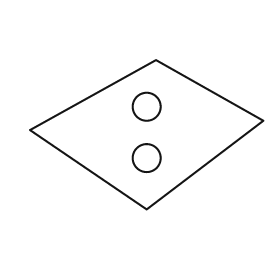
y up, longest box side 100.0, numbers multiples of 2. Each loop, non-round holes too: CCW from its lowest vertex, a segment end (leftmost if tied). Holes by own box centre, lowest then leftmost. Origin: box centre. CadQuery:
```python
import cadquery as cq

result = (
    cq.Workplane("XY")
    .moveTo(0.0, -32.0)
    .lineTo(50.0, 6.0)
    .lineTo(4.0, 32.0)
    .lineTo(-50.0, 2.0)
    .close()
    .moveTo(0.0, -10.0)
    .circle(6.0)
    .moveTo(0.0, 12.0)
    .circle(6.0)
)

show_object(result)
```